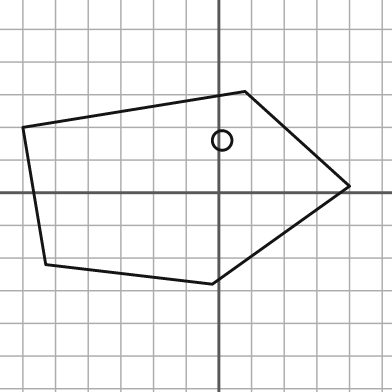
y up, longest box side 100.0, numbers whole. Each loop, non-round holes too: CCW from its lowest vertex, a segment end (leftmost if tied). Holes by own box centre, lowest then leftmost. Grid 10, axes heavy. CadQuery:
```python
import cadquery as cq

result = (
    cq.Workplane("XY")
    .moveTo(-2.0, -28.0)
    .lineTo(40.0, 2.0)
    .lineTo(8.0, 31.0)
    .lineTo(-60.0, 20.0)
    .lineTo(-53.0, -22.0)
    .close()
    .moveTo(1.0, 16.0)
    .circle(3.0)
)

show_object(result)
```